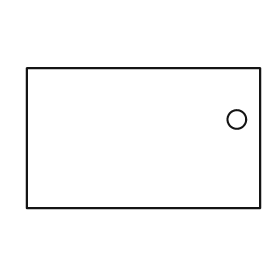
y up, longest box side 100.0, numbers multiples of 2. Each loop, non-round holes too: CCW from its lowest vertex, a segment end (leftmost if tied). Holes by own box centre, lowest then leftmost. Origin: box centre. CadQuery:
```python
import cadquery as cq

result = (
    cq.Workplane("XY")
    .moveTo(-50.0, -30.0)
    .lineTo(50.0, -30.0)
    .lineTo(50.0, 30.0)
    .lineTo(-50.0, 30.0)
    .close()
    .moveTo(40.0, 8.0)
    .circle(4.0)
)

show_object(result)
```